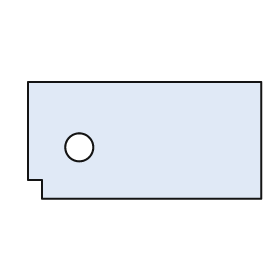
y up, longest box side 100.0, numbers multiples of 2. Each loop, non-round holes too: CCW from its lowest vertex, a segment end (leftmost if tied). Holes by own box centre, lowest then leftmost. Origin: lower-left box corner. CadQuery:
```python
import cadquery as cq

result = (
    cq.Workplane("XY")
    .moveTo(6.0, 0.0)
    .lineTo(100.0, 0.0)
    .lineTo(100.0, 50.0)
    .lineTo(0.0, 50.0)
    .lineTo(0.0, 8.0)
    .lineTo(6.0, 8.0)
    .close()
    .moveTo(22.0, 22.0)
    .circle(6.0)
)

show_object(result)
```